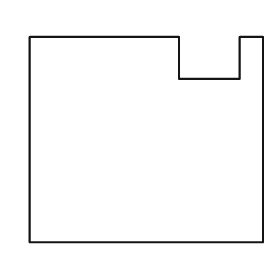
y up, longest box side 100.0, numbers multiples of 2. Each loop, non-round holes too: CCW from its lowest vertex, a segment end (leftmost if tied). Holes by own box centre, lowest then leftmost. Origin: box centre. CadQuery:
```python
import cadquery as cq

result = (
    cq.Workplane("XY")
    .moveTo(-50.0, -44.0)
    .lineTo(50.0, -44.0)
    .lineTo(50.0, 44.0)
    .lineTo(40.0, 44.0)
    .lineTo(40.0, 26.0)
    .lineTo(14.0, 26.0)
    .lineTo(14.0, 44.0)
    .lineTo(-50.0, 44.0)
    .close()
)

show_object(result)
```